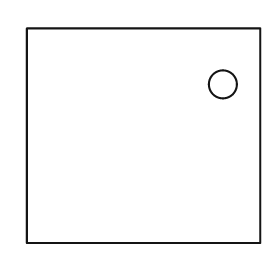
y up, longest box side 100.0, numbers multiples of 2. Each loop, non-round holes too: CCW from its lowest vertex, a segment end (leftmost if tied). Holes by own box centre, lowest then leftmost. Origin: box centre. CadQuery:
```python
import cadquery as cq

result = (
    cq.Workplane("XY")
    .moveTo(-50.0, -46.0)
    .lineTo(50.0, -46.0)
    .lineTo(50.0, 46.0)
    .lineTo(-50.0, 46.0)
    .close()
    .moveTo(34.0, 22.0)
    .circle(6.0)
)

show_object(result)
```